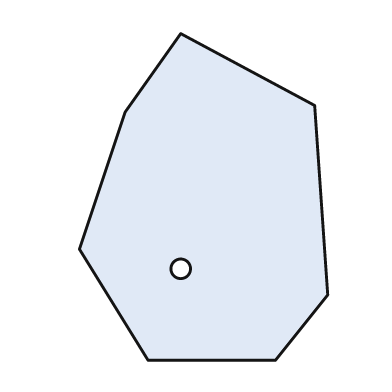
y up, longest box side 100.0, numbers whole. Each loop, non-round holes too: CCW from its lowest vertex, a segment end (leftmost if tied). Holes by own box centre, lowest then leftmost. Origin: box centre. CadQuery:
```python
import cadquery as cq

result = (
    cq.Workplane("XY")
    .moveTo(-17.0, -50.0)
    .lineTo(22.0, -50.0)
    .lineTo(38.0, -30.0)
    .lineTo(34.0, 28.0)
    .lineTo(-7.0, 50.0)
    .lineTo(-24.0, 26.0)
    .lineTo(-38.0, -16.0)
    .close()
    .moveTo(-7.0, -22.0)
    .circle(3.0)
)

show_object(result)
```